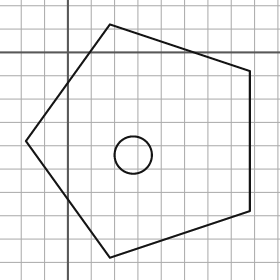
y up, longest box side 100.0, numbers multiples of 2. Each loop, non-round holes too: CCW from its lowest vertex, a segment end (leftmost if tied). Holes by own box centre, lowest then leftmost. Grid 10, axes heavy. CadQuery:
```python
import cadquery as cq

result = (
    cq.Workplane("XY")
    .moveTo(18.0, -88.0)
    .lineTo(78.0, -68.0)
    .lineTo(78.0, -8.0)
    .lineTo(18.0, 12.0)
    .lineTo(-18.0, -38.0)
    .close()
    .moveTo(28.0, -44.0)
    .circle(8.0)
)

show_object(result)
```